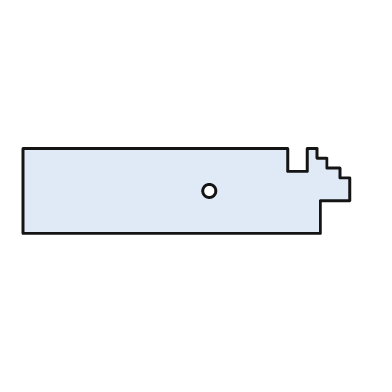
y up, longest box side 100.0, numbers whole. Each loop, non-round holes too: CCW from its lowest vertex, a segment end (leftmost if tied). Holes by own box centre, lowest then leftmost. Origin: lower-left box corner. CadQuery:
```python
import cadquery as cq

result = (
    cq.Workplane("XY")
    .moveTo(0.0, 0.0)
    .lineTo(91.0, 0.0)
    .lineTo(91.0, 10.0)
    .lineTo(100.0, 10.0)
    .lineTo(100.0, 17.0)
    .lineTo(97.0, 17.0)
    .lineTo(97.0, 20.0)
    .lineTo(93.0, 20.0)
    .lineTo(93.0, 23.0)
    .lineTo(90.0, 23.0)
    .lineTo(90.0, 26.0)
    .lineTo(87.0, 26.0)
    .lineTo(87.0, 19.0)
    .lineTo(81.0, 19.0)
    .lineTo(81.0, 26.0)
    .lineTo(0.0, 26.0)
    .close()
    .moveTo(57.0, 13.0)
    .circle(2.0)
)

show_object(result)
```